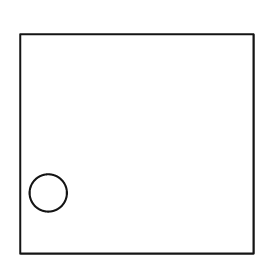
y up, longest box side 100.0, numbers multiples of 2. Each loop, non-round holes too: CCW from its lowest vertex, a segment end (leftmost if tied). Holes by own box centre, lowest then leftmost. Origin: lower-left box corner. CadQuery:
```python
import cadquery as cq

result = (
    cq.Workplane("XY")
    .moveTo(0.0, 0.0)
    .lineTo(100.0, 0.0)
    .lineTo(100.0, 94.0)
    .lineTo(0.0, 94.0)
    .close()
    .moveTo(12.0, 26.0)
    .circle(8.0)
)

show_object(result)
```